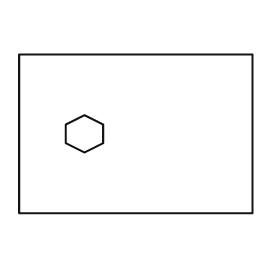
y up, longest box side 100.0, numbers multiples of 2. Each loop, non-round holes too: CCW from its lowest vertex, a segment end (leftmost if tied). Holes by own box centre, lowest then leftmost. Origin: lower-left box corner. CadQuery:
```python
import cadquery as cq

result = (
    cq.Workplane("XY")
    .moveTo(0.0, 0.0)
    .lineTo(100.0, 0.0)
    .lineTo(100.0, 68.0)
    .lineTo(0.0, 68.0)
    .close()
    .moveTo(28.0, 26.0)
    .lineTo(36.0, 30.0)
    .lineTo(36.0, 38.0)
    .lineTo(28.0, 42.0)
    .lineTo(20.0, 38.0)
    .lineTo(20.0, 30.0)
    .close()
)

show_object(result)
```